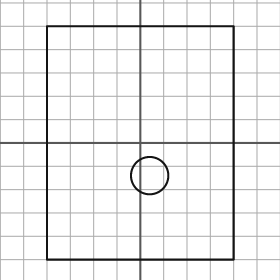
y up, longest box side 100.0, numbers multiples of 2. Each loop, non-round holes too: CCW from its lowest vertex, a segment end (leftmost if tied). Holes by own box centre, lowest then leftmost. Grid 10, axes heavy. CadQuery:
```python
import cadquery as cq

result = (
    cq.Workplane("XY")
    .moveTo(-40.0, -50.0)
    .lineTo(40.0, -50.0)
    .lineTo(40.0, 50.0)
    .lineTo(-40.0, 50.0)
    .close()
    .moveTo(4.0, -14.0)
    .circle(8.0)
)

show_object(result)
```